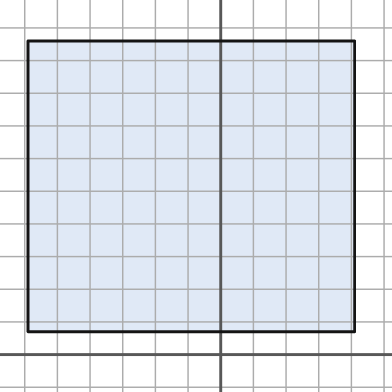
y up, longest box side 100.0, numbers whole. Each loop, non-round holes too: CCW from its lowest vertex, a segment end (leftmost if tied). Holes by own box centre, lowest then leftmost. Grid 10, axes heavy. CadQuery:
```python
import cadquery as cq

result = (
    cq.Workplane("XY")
    .moveTo(-59.0, 7.0)
    .lineTo(41.0, 7.0)
    .lineTo(41.0, 96.0)
    .lineTo(-59.0, 96.0)
    .close()
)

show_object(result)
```